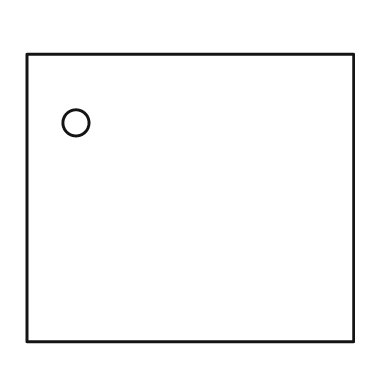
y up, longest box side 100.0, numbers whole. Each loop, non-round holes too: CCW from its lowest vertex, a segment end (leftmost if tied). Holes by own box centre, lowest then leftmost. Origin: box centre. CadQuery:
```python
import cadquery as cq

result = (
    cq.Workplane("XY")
    .moveTo(-50.0, -44.0)
    .lineTo(50.0, -44.0)
    .lineTo(50.0, 44.0)
    .lineTo(-50.0, 44.0)
    .close()
    .moveTo(-35.0, 23.0)
    .circle(4.0)
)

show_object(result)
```